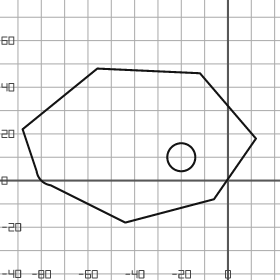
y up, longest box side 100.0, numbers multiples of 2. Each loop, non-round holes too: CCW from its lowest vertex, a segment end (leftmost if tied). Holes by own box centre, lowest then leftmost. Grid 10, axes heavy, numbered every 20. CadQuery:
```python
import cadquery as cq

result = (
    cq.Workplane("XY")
    .moveTo(-44.0, -18.0)
    .lineTo(-6.0, -8.0)
    .lineTo(12.0, 18.0)
    .lineTo(-12.0, 46.0)
    .lineTo(-56.0, 48.0)
    .lineTo(-88.0, 22.0)
    .lineTo(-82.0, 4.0)
    .threePointArc((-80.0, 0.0), (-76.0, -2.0))
    .close()
    .moveTo(-20.0, 10.0)
    .circle(6.0)
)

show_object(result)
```